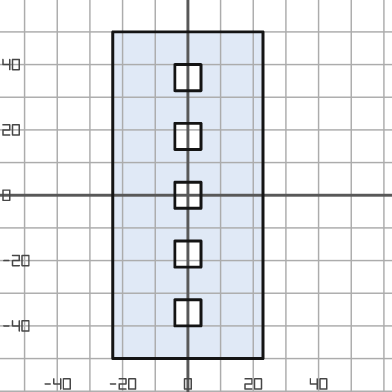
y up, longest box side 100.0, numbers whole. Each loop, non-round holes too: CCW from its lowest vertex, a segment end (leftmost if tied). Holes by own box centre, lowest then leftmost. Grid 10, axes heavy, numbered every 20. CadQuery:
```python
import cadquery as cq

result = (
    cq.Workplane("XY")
    .moveTo(-23.0, -50.0)
    .lineTo(23.0, -50.0)
    .lineTo(23.0, 50.0)
    .lineTo(-23.0, 50.0)
    .close()
    .moveTo(-4.0, -40.0)
    .lineTo(4.0, -40.0)
    .lineTo(4.0, -32.0)
    .lineTo(-4.0, -32.0)
    .close()
    .moveTo(-4.0, -22.0)
    .lineTo(4.0, -22.0)
    .lineTo(4.0, -14.0)
    .lineTo(-4.0, -14.0)
    .close()
    .moveTo(-4.0, -4.0)
    .lineTo(4.0, -4.0)
    .lineTo(4.0, 4.0)
    .lineTo(-4.0, 4.0)
    .close()
    .moveTo(-4.0, 14.0)
    .lineTo(4.0, 14.0)
    .lineTo(4.0, 22.0)
    .lineTo(-4.0, 22.0)
    .close()
    .moveTo(-4.0, 32.0)
    .lineTo(4.0, 32.0)
    .lineTo(4.0, 40.0)
    .lineTo(-4.0, 40.0)
    .close()
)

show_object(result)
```